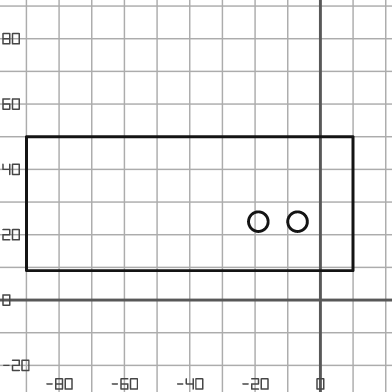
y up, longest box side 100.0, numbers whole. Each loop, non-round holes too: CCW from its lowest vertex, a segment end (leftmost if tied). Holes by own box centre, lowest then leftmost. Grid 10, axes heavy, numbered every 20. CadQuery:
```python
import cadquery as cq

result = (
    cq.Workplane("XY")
    .moveTo(-90.0, 9.0)
    .lineTo(10.0, 9.0)
    .lineTo(10.0, 50.0)
    .lineTo(-90.0, 50.0)
    .close()
    .moveTo(-19.0, 24.0)
    .circle(3.0)
    .moveTo(-7.0, 24.0)
    .circle(3.0)
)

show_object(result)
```